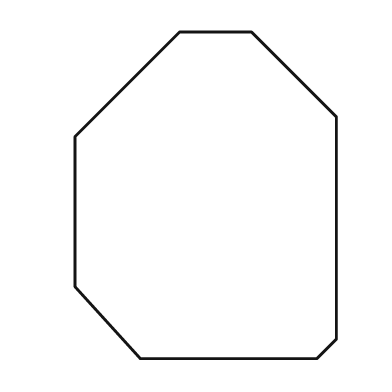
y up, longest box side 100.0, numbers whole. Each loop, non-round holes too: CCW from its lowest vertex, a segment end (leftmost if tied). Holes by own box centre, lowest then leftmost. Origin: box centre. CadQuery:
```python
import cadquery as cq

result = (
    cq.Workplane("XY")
    .moveTo(-20.0, -50.0)
    .lineTo(34.0, -50.0)
    .lineTo(40.0, -44.0)
    .lineTo(40.0, 24.0)
    .lineTo(14.0, 50.0)
    .lineTo(-8.0, 50.0)
    .lineTo(-40.0, 18.0)
    .lineTo(-40.0, -28.0)
    .close()
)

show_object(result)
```